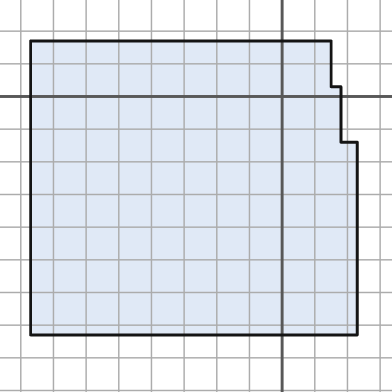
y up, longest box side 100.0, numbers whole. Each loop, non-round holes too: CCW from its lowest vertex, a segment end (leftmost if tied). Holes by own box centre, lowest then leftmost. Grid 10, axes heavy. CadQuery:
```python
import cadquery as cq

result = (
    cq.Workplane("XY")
    .moveTo(-77.0, -73.0)
    .lineTo(23.0, -73.0)
    .lineTo(23.0, -14.0)
    .lineTo(18.0, -14.0)
    .lineTo(18.0, 3.0)
    .lineTo(15.0, 3.0)
    .lineTo(15.0, 17.0)
    .lineTo(-77.0, 17.0)
    .close()
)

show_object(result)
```